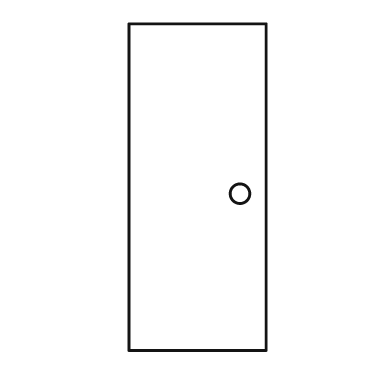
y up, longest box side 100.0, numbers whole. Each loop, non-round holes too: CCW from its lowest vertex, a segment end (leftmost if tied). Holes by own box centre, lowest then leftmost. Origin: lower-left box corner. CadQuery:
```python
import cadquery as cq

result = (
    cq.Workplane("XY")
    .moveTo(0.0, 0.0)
    .lineTo(42.0, 0.0)
    .lineTo(42.0, 100.0)
    .lineTo(0.0, 100.0)
    .close()
    .moveTo(34.0, 48.0)
    .circle(3.0)
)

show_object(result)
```